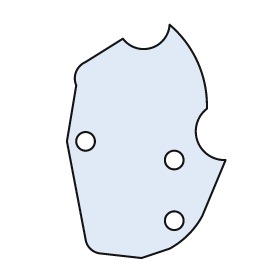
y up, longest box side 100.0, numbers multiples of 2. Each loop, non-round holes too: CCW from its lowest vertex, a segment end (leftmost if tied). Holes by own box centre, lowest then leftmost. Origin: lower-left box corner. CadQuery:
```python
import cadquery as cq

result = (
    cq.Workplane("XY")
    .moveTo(32.0, 0.0)
    .lineTo(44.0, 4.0)
    .threePointArc((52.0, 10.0), (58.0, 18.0))
    .lineTo(68.0, 42.0)
    .threePointArc((56.0, 50.0), (60.0, 64.0))
    .threePointArc((56.0, 84.0), (44.0, 100.0))
    .threePointArc((36.0, 90.0), (24.0, 94.0))
    .lineTo(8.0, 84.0)
    .threePointArc((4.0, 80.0), (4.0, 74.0))
    .lineTo(0.0, 50.0)
    .lineTo(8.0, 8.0)
    .threePointArc((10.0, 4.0), (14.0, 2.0))
    .close()
    .moveTo(46.0, 16.0)
    .circle(4.0)
    .moveTo(46.0, 42.0)
    .circle(4.0)
    .moveTo(8.0, 50.0)
    .circle(4.0)
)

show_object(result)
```